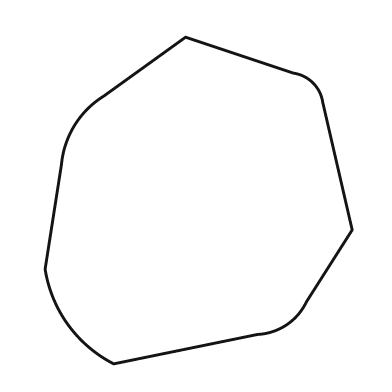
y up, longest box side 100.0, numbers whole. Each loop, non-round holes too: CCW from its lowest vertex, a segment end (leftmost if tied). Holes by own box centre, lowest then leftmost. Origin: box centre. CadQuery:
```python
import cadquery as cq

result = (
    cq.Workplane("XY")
    .moveTo(-26.0, -50.0)
    .lineTo(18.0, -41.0)
    .threePointArc((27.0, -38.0), (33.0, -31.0))
    .lineTo(47.0, -9.0)
    .lineTo(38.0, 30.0)
    .threePointArc((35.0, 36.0), (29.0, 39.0))
    .lineTo(-4.0, 50.0)
    .lineTo(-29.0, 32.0)
    .threePointArc((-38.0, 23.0), (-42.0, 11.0))
    .lineTo(-47.0, -21.0)
    .threePointArc((-40.0, -38.0), (-26.0, -50.0))
    .close()
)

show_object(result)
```